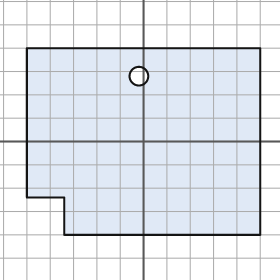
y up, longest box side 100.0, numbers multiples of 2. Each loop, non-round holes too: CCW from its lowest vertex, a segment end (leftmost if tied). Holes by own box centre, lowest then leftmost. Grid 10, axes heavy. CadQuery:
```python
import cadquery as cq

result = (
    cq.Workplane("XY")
    .moveTo(-34.0, -40.0)
    .lineTo(50.0, -40.0)
    .lineTo(50.0, 40.0)
    .lineTo(-50.0, 40.0)
    .lineTo(-50.0, -24.0)
    .lineTo(-34.0, -24.0)
    .close()
    .moveTo(-2.0, 28.0)
    .circle(4.0)
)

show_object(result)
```